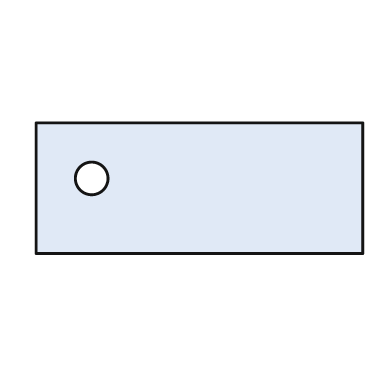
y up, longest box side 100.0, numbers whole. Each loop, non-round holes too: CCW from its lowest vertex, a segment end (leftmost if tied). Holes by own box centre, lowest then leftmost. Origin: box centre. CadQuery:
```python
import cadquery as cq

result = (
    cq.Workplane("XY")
    .moveTo(-50.0, -20.0)
    .lineTo(50.0, -20.0)
    .lineTo(50.0, 20.0)
    .lineTo(-50.0, 20.0)
    .close()
    .moveTo(-33.0, 3.0)
    .circle(5.0)
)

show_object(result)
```